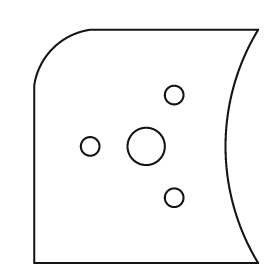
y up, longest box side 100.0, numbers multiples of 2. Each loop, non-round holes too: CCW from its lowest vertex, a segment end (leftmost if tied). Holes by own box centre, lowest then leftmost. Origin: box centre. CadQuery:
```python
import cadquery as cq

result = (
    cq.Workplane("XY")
    .moveTo(-48.0, -50.0)
    .lineTo(48.0, -50.0)
    .threePointArc((34.0, 0.0), (48.0, 50.0))
    .lineTo(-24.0, 50.0)
    .threePointArc((-40.0, 42.0), (-48.0, 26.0))
    .close()
    .moveTo(12.0, -22.0)
    .circle(4.0)
    .moveTo(-24.0, 0.0)
    .circle(4.0)
    .moveTo(0.0, 0.0)
    .circle(8.0)
    .moveTo(12.0, 22.0)
    .circle(4.0)
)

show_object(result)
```